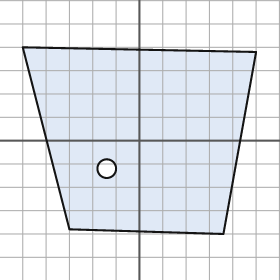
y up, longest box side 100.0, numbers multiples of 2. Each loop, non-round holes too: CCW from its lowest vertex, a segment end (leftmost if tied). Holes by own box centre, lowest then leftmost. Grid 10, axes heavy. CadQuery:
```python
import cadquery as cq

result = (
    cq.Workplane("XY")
    .moveTo(36.0, -40.0)
    .lineTo(50.0, 38.0)
    .lineTo(-50.0, 40.0)
    .lineTo(-30.0, -38.0)
    .close()
    .moveTo(-14.0, -12.0)
    .circle(4.0)
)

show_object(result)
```